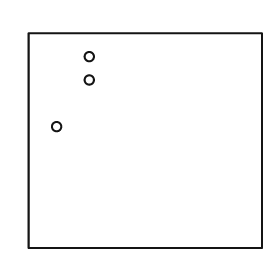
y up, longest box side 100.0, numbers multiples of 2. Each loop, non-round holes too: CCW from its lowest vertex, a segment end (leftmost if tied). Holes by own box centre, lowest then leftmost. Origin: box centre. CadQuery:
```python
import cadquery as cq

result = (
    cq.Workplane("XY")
    .moveTo(-50.0, -46.0)
    .lineTo(50.0, -46.0)
    .lineTo(50.0, 46.0)
    .lineTo(-50.0, 46.0)
    .close()
    .moveTo(-38.0, 6.0)
    .circle(2.0)
    .moveTo(-24.0, 26.0)
    .circle(2.0)
    .moveTo(-24.0, 36.0)
    .circle(2.0)
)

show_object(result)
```